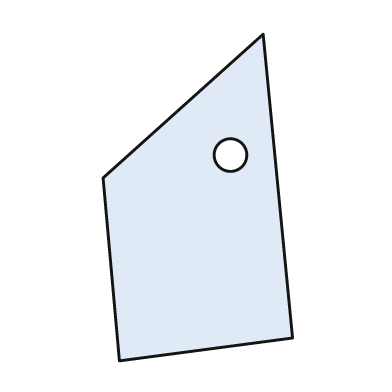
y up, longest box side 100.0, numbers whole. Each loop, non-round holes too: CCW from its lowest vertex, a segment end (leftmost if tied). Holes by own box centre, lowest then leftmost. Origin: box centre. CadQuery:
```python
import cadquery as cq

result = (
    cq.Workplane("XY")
    .moveTo(-24.0, -50.0)
    .lineTo(29.0, -43.0)
    .lineTo(20.0, 50.0)
    .lineTo(-29.0, 6.0)
    .close()
    .moveTo(10.0, 13.0)
    .circle(5.0)
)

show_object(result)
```